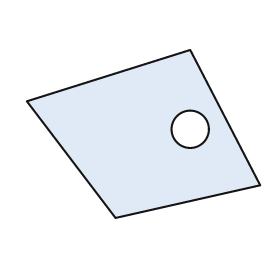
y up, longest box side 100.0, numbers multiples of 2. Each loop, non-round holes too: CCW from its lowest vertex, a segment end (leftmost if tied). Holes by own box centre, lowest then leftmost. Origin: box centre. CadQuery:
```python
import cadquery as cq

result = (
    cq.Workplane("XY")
    .moveTo(-12.0, -36.0)
    .lineTo(50.0, -22.0)
    .lineTo(20.0, 36.0)
    .lineTo(-50.0, 14.0)
    .close()
    .moveTo(20.0, 2.0)
    .circle(8.0)
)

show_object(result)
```